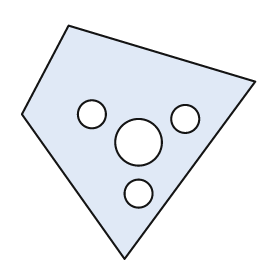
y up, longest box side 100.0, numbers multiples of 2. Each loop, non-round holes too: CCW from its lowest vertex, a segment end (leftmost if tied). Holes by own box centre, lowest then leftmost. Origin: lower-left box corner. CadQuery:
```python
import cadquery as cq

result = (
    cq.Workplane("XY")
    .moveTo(44.0, 0.0)
    .lineTo(100.0, 76.0)
    .lineTo(20.0, 100.0)
    .lineTo(0.0, 62.0)
    .close()
    .moveTo(50.0, 28.0)
    .circle(6.0)
    .moveTo(50.0, 50.0)
    .circle(10.0)
    .moveTo(70.0, 60.0)
    .circle(6.0)
    .moveTo(30.0, 62.0)
    .circle(6.0)
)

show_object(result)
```